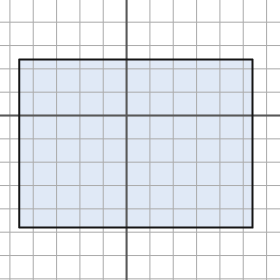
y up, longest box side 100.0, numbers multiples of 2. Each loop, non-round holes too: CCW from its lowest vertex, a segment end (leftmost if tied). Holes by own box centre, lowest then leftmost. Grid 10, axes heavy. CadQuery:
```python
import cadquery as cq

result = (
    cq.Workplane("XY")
    .moveTo(-46.0, -48.0)
    .lineTo(54.0, -48.0)
    .lineTo(54.0, 24.0)
    .lineTo(-46.0, 24.0)
    .close()
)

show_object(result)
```